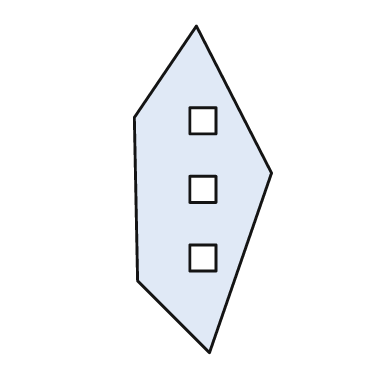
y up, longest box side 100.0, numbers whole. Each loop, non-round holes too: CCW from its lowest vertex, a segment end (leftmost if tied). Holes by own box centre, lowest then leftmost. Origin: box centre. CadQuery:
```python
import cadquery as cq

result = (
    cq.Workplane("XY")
    .moveTo(2.0, -50.0)
    .lineTo(21.0, 5.0)
    .lineTo(-2.0, 50.0)
    .lineTo(-21.0, 22.0)
    .lineTo(-20.0, -28.0)
    .close()
    .moveTo(-4.0, -25.0)
    .lineTo(4.0, -25.0)
    .lineTo(4.0, -17.0)
    .lineTo(-4.0, -17.0)
    .close()
    .moveTo(-4.0, -4.0)
    .lineTo(4.0, -4.0)
    .lineTo(4.0, 4.0)
    .lineTo(-4.0, 4.0)
    .close()
    .moveTo(-4.0, 17.0)
    .lineTo(4.0, 17.0)
    .lineTo(4.0, 25.0)
    .lineTo(-4.0, 25.0)
    .close()
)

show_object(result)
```